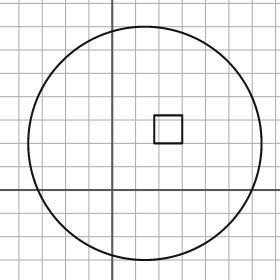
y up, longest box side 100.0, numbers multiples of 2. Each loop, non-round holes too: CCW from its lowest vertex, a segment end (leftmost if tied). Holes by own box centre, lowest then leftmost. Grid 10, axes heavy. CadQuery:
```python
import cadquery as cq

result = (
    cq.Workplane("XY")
    .moveTo(14.0, 20.0)
    .circle(50.0)
    .moveTo(18.0, 20.0)
    .lineTo(30.0, 20.0)
    .lineTo(30.0, 32.0)
    .lineTo(18.0, 32.0)
    .close()
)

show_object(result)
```